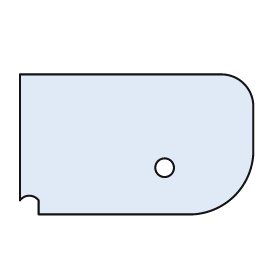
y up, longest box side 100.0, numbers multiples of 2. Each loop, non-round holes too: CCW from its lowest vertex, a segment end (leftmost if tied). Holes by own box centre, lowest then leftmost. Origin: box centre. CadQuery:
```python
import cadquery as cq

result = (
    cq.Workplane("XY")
    .moveTo(-42.0, -30.0)
    .lineTo(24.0, -30.0)
    .threePointArc((42.0, -22.0), (50.0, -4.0))
    .lineTo(50.0, 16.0)
    .threePointArc((46.0, 26.0), (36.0, 30.0))
    .lineTo(-50.0, 30.0)
    .lineTo(-50.0, -24.0)
    .threePointArc((-46.0, -22.0), (-42.0, -24.0))
    .close()
    .moveTo(12.0, -10.0)
    .circle(4.0)
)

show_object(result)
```